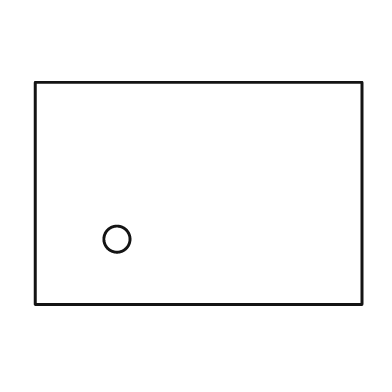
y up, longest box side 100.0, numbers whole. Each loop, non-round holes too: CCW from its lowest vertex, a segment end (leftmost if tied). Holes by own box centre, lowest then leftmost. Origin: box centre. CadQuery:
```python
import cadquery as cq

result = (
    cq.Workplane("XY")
    .moveTo(-50.0, -34.0)
    .lineTo(50.0, -34.0)
    .lineTo(50.0, 34.0)
    .lineTo(-50.0, 34.0)
    .close()
    .moveTo(-25.0, -14.0)
    .circle(4.0)
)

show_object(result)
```